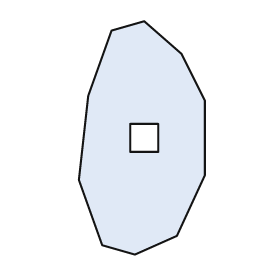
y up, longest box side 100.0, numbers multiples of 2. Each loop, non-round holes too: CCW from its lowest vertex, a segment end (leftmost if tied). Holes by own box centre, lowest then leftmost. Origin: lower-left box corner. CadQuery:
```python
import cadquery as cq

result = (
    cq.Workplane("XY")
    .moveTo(24.0, 0.0)
    .lineTo(42.0, 8.0)
    .lineTo(54.0, 34.0)
    .lineTo(54.0, 66.0)
    .lineTo(44.0, 86.0)
    .lineTo(28.0, 100.0)
    .lineTo(14.0, 96.0)
    .lineTo(4.0, 68.0)
    .lineTo(0.0, 32.0)
    .lineTo(10.0, 4.0)
    .close()
    .moveTo(22.0, 44.0)
    .lineTo(34.0, 44.0)
    .lineTo(34.0, 56.0)
    .lineTo(22.0, 56.0)
    .close()
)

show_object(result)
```